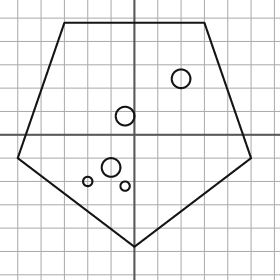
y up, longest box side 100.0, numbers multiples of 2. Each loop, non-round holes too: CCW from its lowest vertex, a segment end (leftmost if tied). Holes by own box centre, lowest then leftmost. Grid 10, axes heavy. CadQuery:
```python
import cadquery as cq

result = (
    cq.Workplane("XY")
    .moveTo(0.0, -48.0)
    .lineTo(50.0, -10.0)
    .lineTo(30.0, 48.0)
    .lineTo(-30.0, 48.0)
    .lineTo(-50.0, -10.0)
    .close()
    .moveTo(-4.0, -22.0)
    .circle(2.0)
    .moveTo(-20.0, -20.0)
    .circle(2.0)
    .moveTo(-10.0, -14.0)
    .circle(4.0)
    .moveTo(-4.0, 8.0)
    .circle(4.0)
    .moveTo(20.0, 24.0)
    .circle(4.0)
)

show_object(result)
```